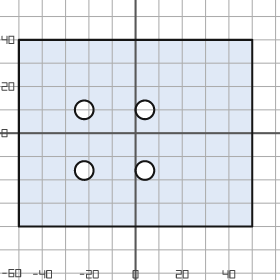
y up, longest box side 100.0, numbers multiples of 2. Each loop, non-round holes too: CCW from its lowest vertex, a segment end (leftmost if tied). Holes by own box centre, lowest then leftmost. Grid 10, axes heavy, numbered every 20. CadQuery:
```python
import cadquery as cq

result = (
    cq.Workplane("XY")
    .moveTo(-50.0, -40.0)
    .lineTo(50.0, -40.0)
    .lineTo(50.0, 40.0)
    .lineTo(-50.0, 40.0)
    .close()
    .moveTo(-22.0, -16.0)
    .circle(4.0)
    .moveTo(4.0, -16.0)
    .circle(4.0)
    .moveTo(-22.0, 10.0)
    .circle(4.0)
    .moveTo(4.0, 10.0)
    .circle(4.0)
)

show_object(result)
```